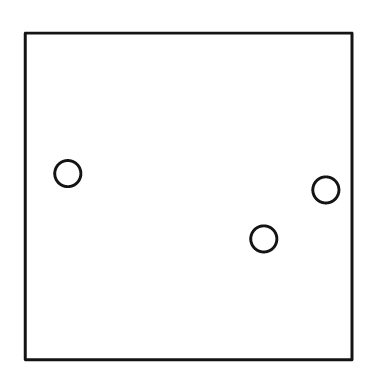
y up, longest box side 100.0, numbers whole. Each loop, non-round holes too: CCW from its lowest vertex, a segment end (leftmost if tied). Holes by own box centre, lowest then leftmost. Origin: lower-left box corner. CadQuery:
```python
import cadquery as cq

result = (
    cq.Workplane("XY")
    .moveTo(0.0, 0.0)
    .lineTo(100.0, 0.0)
    .lineTo(100.0, 100.0)
    .lineTo(0.0, 100.0)
    .close()
    .moveTo(73.0, 37.0)
    .circle(4.0)
    .moveTo(92.0, 52.0)
    .circle(4.0)
    .moveTo(13.0, 57.0)
    .circle(4.0)
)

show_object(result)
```